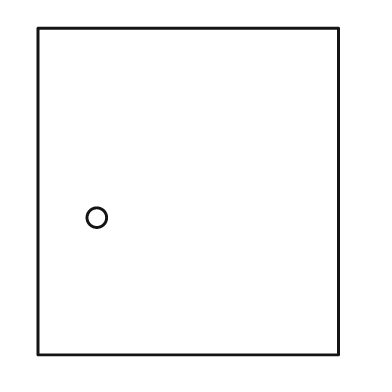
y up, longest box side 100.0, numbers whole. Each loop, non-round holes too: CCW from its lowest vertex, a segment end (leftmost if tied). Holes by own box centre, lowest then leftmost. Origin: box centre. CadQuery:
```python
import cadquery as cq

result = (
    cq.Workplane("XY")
    .moveTo(-46.0, -50.0)
    .lineTo(46.0, -50.0)
    .lineTo(46.0, 50.0)
    .lineTo(-46.0, 50.0)
    .close()
    .moveTo(-28.0, -8.0)
    .circle(3.0)
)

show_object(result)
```